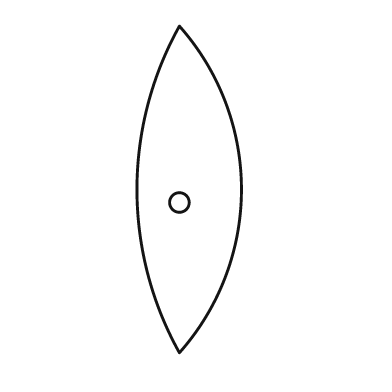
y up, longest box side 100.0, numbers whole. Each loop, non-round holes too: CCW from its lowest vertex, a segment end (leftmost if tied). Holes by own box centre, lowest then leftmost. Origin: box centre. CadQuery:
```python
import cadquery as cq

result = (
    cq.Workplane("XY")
    .moveTo(-3.0, -50.0)
    .threePointArc((16.0, 0.0), (-3.0, 50.0))
    .threePointArc((-16.0, 0.0), (-3.0, -50.0))
    .close()
    .moveTo(-3.0, -4.0)
    .circle(3.0)
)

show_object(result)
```